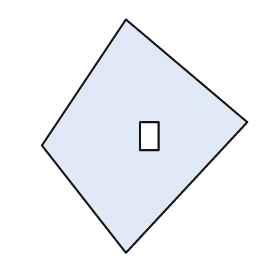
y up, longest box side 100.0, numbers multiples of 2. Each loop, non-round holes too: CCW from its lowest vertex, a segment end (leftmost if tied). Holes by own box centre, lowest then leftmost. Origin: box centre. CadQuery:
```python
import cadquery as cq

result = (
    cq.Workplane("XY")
    .moveTo(-8.0, -50.0)
    .lineTo(44.0, 6.0)
    .lineTo(-8.0, 50.0)
    .lineTo(-44.0, -4.0)
    .close()
    .moveTo(-2.0, -6.0)
    .lineTo(6.0, -6.0)
    .lineTo(6.0, 6.0)
    .lineTo(-2.0, 6.0)
    .close()
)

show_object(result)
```